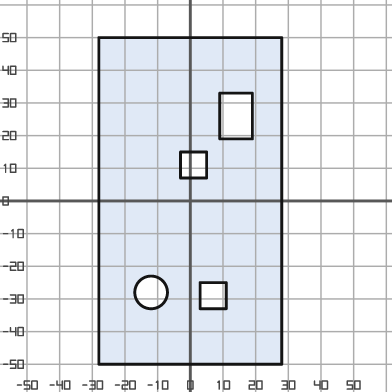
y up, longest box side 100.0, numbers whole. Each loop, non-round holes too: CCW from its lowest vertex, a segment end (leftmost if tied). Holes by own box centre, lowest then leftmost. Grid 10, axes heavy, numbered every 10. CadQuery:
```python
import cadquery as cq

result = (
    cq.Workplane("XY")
    .moveTo(-28.0, -50.0)
    .lineTo(28.0, -50.0)
    .lineTo(28.0, 50.0)
    .lineTo(-28.0, 50.0)
    .close()
    .moveTo(3.0, -33.0)
    .lineTo(11.0, -33.0)
    .lineTo(11.0, -25.0)
    .lineTo(3.0, -25.0)
    .close()
    .moveTo(-12.0, -28.0)
    .circle(5.0)
    .moveTo(-3.0, 7.0)
    .lineTo(5.0, 7.0)
    .lineTo(5.0, 15.0)
    .lineTo(-3.0, 15.0)
    .close()
    .moveTo(9.0, 19.0)
    .lineTo(19.0, 19.0)
    .lineTo(19.0, 33.0)
    .lineTo(9.0, 33.0)
    .close()
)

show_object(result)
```